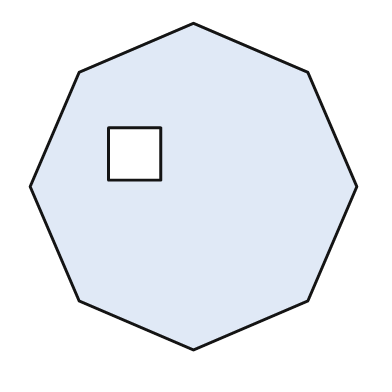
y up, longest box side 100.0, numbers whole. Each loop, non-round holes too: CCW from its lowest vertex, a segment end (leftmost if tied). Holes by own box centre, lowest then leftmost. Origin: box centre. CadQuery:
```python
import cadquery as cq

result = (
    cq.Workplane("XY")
    .moveTo(0.0, -50.0)
    .lineTo(35.0, -35.0)
    .lineTo(50.0, 0.0)
    .lineTo(35.0, 35.0)
    .lineTo(0.0, 50.0)
    .lineTo(-35.0, 35.0)
    .lineTo(-50.0, 0.0)
    .lineTo(-35.0, -35.0)
    .close()
    .moveTo(-26.0, 2.0)
    .lineTo(-10.0, 2.0)
    .lineTo(-10.0, 18.0)
    .lineTo(-26.0, 18.0)
    .close()
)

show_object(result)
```